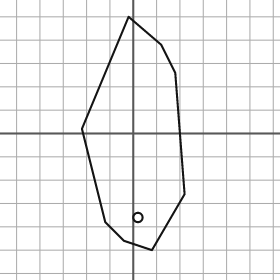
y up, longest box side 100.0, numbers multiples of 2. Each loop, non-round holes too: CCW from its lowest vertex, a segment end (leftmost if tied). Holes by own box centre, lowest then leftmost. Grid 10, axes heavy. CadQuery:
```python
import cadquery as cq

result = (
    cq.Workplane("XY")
    .moveTo(8.0, -50.0)
    .lineTo(22.0, -26.0)
    .lineTo(18.0, 26.0)
    .lineTo(12.0, 38.0)
    .lineTo(-2.0, 50.0)
    .lineTo(-22.0, 2.0)
    .lineTo(-12.0, -38.0)
    .lineTo(-4.0, -46.0)
    .close()
    .moveTo(2.0, -36.0)
    .circle(2.0)
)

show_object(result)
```